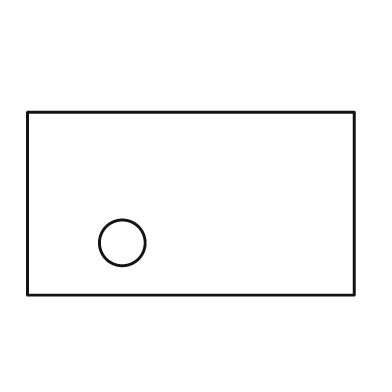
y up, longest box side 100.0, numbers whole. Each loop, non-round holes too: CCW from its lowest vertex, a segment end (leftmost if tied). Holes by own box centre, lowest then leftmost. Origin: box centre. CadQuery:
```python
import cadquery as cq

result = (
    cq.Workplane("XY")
    .moveTo(-50.0, -28.0)
    .lineTo(50.0, -28.0)
    .lineTo(50.0, 28.0)
    .lineTo(-50.0, 28.0)
    .close()
    .moveTo(-21.0, -12.0)
    .circle(7.0)
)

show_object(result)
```